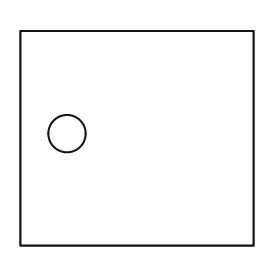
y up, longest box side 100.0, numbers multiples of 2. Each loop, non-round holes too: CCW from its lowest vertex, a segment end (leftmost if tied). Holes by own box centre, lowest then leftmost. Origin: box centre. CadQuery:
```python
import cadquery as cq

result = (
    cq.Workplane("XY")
    .moveTo(-50.0, -46.0)
    .lineTo(50.0, -46.0)
    .lineTo(50.0, 46.0)
    .lineTo(-50.0, 46.0)
    .close()
    .moveTo(-30.0, 2.0)
    .circle(8.0)
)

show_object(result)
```